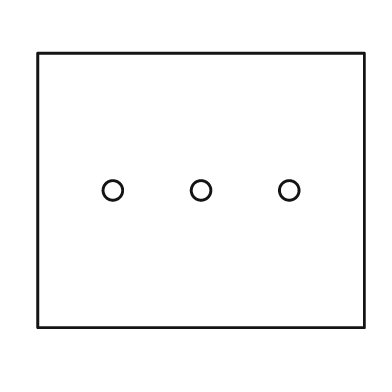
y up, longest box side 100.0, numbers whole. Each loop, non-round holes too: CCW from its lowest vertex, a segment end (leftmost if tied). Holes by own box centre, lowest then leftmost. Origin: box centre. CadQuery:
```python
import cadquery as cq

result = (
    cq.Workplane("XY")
    .moveTo(-50.0, -42.0)
    .lineTo(50.0, -42.0)
    .lineTo(50.0, 42.0)
    .lineTo(-50.0, 42.0)
    .close()
    .moveTo(-27.0, 0.0)
    .circle(3.0)
    .moveTo(0.0, 0.0)
    .circle(3.0)
    .moveTo(27.0, 0.0)
    .circle(3.0)
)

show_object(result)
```